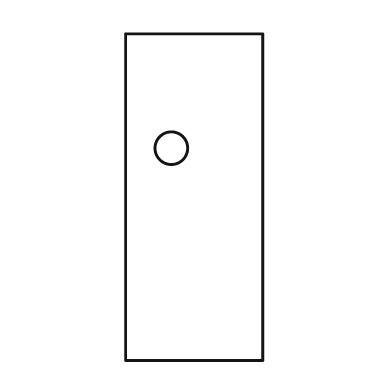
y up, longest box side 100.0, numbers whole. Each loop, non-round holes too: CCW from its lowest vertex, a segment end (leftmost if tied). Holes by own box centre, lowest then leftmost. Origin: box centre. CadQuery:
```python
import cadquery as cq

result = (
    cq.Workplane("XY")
    .moveTo(-21.0, -50.0)
    .lineTo(21.0, -50.0)
    .lineTo(21.0, 50.0)
    .lineTo(-21.0, 50.0)
    .close()
    .moveTo(-7.0, 15.0)
    .circle(5.0)
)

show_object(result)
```